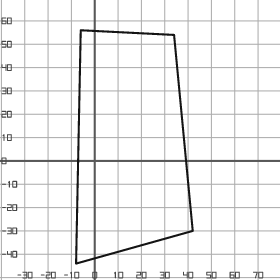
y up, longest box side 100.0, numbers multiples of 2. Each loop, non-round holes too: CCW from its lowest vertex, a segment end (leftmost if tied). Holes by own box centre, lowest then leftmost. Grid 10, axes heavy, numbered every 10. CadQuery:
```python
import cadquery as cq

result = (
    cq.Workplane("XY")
    .moveTo(-8.0, -44.0)
    .lineTo(42.0, -30.0)
    .lineTo(34.0, 54.0)
    .lineTo(-6.0, 56.0)
    .close()
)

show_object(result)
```